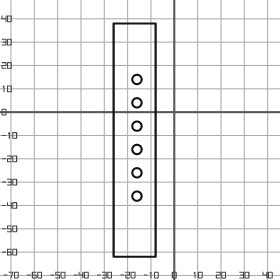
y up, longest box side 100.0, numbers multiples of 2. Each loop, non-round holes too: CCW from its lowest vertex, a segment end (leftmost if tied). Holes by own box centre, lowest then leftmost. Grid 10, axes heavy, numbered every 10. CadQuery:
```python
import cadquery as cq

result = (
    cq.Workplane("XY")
    .moveTo(-26.0, -62.0)
    .lineTo(-8.0, -62.0)
    .lineTo(-8.0, 38.0)
    .lineTo(-26.0, 38.0)
    .close()
    .moveTo(-16.0, -36.0)
    .circle(2.0)
    .moveTo(-16.0, -26.0)
    .circle(2.0)
    .moveTo(-16.0, -16.0)
    .circle(2.0)
    .moveTo(-16.0, -6.0)
    .circle(2.0)
    .moveTo(-16.0, 4.0)
    .circle(2.0)
    .moveTo(-16.0, 14.0)
    .circle(2.0)
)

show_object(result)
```